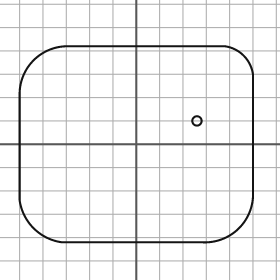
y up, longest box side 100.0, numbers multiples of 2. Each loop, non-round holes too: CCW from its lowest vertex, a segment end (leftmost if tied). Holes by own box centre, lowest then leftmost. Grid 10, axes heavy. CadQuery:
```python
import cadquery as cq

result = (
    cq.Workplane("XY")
    .moveTo(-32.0, -42.0)
    .lineTo(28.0, -42.0)
    .threePointArc((44.0, -36.0), (50.0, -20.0))
    .lineTo(50.0, 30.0)
    .threePointArc((46.0, 38.0), (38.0, 42.0))
    .lineTo(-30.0, 42.0)
    .threePointArc((-44.0, 36.0), (-50.0, 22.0))
    .lineTo(-50.0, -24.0)
    .threePointArc((-44.0, -36.0), (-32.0, -42.0))
    .close()
    .moveTo(26.0, 10.0)
    .circle(2.0)
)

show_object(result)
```